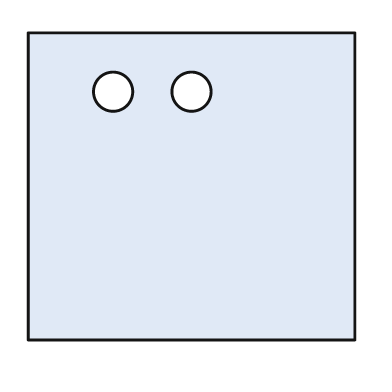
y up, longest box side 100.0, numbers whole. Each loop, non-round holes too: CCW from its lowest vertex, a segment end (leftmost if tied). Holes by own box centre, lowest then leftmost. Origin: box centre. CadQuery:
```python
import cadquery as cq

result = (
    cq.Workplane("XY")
    .moveTo(-50.0, -47.0)
    .lineTo(50.0, -47.0)
    .lineTo(50.0, 47.0)
    .lineTo(-50.0, 47.0)
    .close()
    .moveTo(-24.0, 29.0)
    .circle(6.0)
    .moveTo(0.0, 29.0)
    .circle(6.0)
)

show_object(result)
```